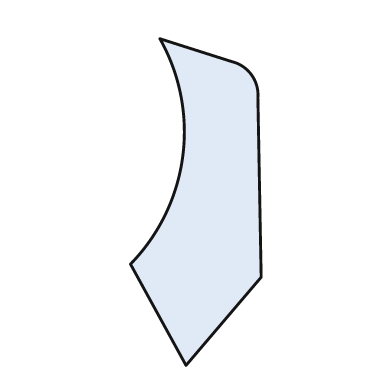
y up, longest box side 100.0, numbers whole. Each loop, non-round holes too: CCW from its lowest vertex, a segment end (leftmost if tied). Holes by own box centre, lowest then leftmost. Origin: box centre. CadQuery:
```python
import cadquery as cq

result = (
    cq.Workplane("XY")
    .moveTo(-3.0, -50.0)
    .lineTo(20.0, -23.0)
    .lineTo(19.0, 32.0)
    .threePointArc((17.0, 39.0), (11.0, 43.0))
    .lineTo(-11.0, 50.0)
    .threePointArc((-4.0, 14.0), (-20.0, -19.0))
    .close()
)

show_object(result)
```